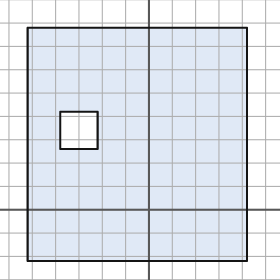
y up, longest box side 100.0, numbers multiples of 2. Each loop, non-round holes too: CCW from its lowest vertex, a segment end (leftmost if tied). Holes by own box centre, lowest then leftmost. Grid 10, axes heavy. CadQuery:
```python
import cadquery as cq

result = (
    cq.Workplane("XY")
    .moveTo(-52.0, -22.0)
    .lineTo(42.0, -22.0)
    .lineTo(42.0, 78.0)
    .lineTo(-52.0, 78.0)
    .close()
    .moveTo(-38.0, 26.0)
    .lineTo(-22.0, 26.0)
    .lineTo(-22.0, 42.0)
    .lineTo(-38.0, 42.0)
    .close()
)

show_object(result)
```